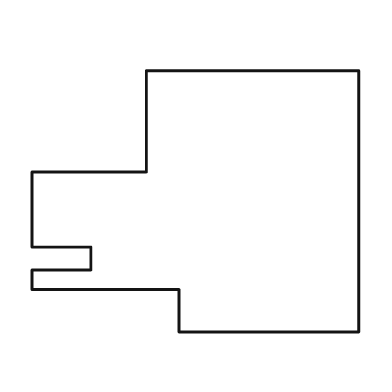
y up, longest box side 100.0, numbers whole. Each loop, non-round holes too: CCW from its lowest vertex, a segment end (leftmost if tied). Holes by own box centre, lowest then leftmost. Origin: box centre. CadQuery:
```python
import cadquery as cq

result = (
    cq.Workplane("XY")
    .moveTo(-5.0, -40.0)
    .lineTo(50.0, -40.0)
    .lineTo(50.0, 40.0)
    .lineTo(-15.0, 40.0)
    .lineTo(-15.0, 9.0)
    .lineTo(-50.0, 9.0)
    .lineTo(-50.0, -14.0)
    .lineTo(-32.0, -14.0)
    .lineTo(-32.0, -21.0)
    .lineTo(-50.0, -21.0)
    .lineTo(-50.0, -27.0)
    .lineTo(-5.0, -27.0)
    .close()
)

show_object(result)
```